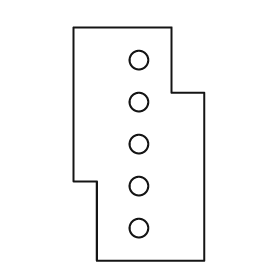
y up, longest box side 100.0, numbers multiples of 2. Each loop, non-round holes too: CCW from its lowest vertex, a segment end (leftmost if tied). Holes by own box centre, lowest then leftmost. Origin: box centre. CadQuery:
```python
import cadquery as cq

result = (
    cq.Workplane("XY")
    .moveTo(-18.0, -50.0)
    .lineTo(28.0, -50.0)
    .lineTo(28.0, 22.0)
    .lineTo(14.0, 22.0)
    .lineTo(14.0, 50.0)
    .lineTo(-28.0, 50.0)
    .lineTo(-28.0, -16.0)
    .lineTo(-18.0, -16.0)
    .close()
    .moveTo(0.0, -36.0)
    .circle(4.0)
    .moveTo(0.0, -18.0)
    .circle(4.0)
    .moveTo(0.0, 0.0)
    .circle(4.0)
    .moveTo(0.0, 18.0)
    .circle(4.0)
    .moveTo(0.0, 36.0)
    .circle(4.0)
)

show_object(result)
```